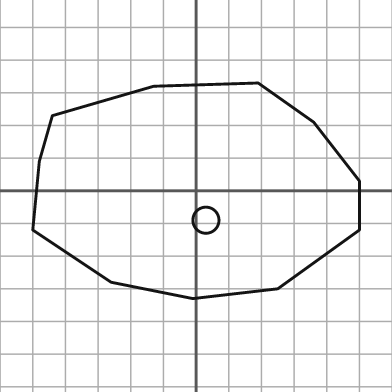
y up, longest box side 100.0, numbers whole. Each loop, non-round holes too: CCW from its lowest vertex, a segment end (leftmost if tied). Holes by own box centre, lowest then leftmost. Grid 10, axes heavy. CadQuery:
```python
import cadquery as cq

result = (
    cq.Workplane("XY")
    .moveTo(-1.0, -33.0)
    .lineTo(25.0, -30.0)
    .lineTo(50.0, -12.0)
    .lineTo(50.0, 3.0)
    .lineTo(36.0, 21.0)
    .lineTo(19.0, 33.0)
    .lineTo(-13.0, 32.0)
    .lineTo(-44.0, 23.0)
    .lineTo(-48.0, 9.0)
    .lineTo(-50.0, -12.0)
    .lineTo(-26.0, -28.0)
    .close()
    .moveTo(3.0, -9.0)
    .circle(4.0)
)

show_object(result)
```